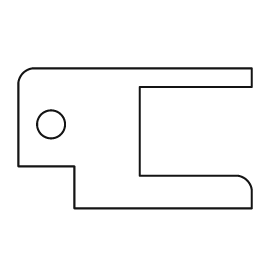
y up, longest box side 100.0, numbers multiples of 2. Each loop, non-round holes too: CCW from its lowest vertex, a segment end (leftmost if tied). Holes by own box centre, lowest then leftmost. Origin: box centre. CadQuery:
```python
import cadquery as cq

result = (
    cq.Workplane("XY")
    .moveTo(-26.0, -30.0)
    .lineTo(50.0, -30.0)
    .lineTo(50.0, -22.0)
    .threePointArc((48.0, -18.0), (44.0, -16.0))
    .lineTo(2.0, -16.0)
    .lineTo(2.0, 22.0)
    .lineTo(50.0, 22.0)
    .lineTo(50.0, 30.0)
    .lineTo(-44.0, 30.0)
    .threePointArc((-48.0, 28.0), (-50.0, 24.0))
    .lineTo(-50.0, -12.0)
    .lineTo(-26.0, -12.0)
    .close()
    .moveTo(-36.0, 6.0)
    .circle(6.0)
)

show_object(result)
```